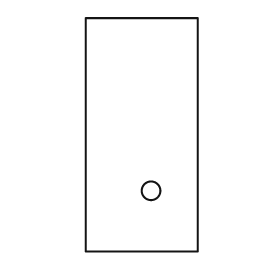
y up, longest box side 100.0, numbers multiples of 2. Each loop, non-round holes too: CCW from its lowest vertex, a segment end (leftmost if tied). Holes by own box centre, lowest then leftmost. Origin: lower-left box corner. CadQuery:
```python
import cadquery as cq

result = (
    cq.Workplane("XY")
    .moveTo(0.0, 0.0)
    .lineTo(48.0, 0.0)
    .lineTo(48.0, 100.0)
    .lineTo(0.0, 100.0)
    .close()
    .moveTo(28.0, 26.0)
    .circle(4.0)
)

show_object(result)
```